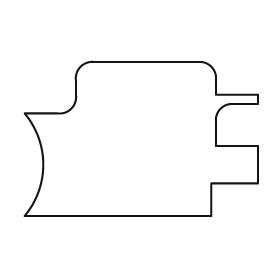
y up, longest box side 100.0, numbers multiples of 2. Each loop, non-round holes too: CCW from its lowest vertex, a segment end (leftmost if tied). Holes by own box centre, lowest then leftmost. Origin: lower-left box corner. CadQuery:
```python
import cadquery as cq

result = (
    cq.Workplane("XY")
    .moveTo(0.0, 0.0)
    .lineTo(80.0, 0.0)
    .lineTo(80.0, 14.0)
    .lineTo(100.0, 14.0)
    .lineTo(100.0, 30.0)
    .lineTo(82.0, 30.0)
    .lineTo(82.0, 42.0)
    .threePointArc((84.0, 46.0), (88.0, 48.0))
    .lineTo(100.0, 48.0)
    .lineTo(100.0, 52.0)
    .lineTo(82.0, 52.0)
    .lineTo(82.0, 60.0)
    .threePointArc((80.0, 64.0), (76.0, 66.0))
    .lineTo(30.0, 66.0)
    .threePointArc((24.0, 64.0), (22.0, 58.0))
    .lineTo(22.0, 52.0)
    .threePointArc((20.0, 46.0), (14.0, 44.0))
    .lineTo(0.0, 44.0)
    .threePointArc((8.0, 22.0), (0.0, 0.0))
    .close()
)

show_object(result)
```